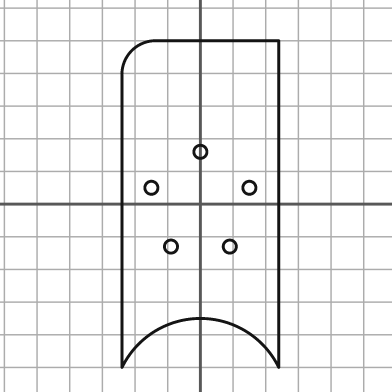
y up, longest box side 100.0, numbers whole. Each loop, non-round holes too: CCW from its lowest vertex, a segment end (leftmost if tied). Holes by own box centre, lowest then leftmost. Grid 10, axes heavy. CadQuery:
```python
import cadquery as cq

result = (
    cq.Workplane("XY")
    .moveTo(-24.0, -50.0)
    .threePointArc((0.0, -35.0), (24.0, -50.0))
    .lineTo(24.0, 50.0)
    .lineTo(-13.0, 50.0)
    .threePointArc((-21.0, 47.0), (-24.0, 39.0))
    .close()
    .moveTo(-9.0, -13.0)
    .circle(2.0)
    .moveTo(9.0, -13.0)
    .circle(2.0)
    .moveTo(-15.0, 5.0)
    .circle(2.0)
    .moveTo(15.0, 5.0)
    .circle(2.0)
    .moveTo(0.0, 16.0)
    .circle(2.0)
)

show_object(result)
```